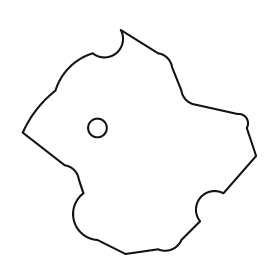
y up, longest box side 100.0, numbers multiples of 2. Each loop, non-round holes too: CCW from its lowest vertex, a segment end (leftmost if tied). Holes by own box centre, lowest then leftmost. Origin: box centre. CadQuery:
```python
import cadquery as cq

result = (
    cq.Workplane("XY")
    .moveTo(-6.0, -48.0)
    .lineTo(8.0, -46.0)
    .threePointArc((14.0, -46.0), (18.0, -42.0))
    .lineTo(26.0, -34.0)
    .threePointArc((26.0, -24.0), (36.0, -22.0))
    .lineTo(50.0, -6.0)
    .lineTo(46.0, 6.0)
    .threePointArc((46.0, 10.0), (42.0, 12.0))
    .lineTo(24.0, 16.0)
    .threePointArc((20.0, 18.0), (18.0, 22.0))
    .lineTo(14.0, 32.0)
    .threePointArc((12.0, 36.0), (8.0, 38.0))
    .lineTo(-8.0, 48.0)
    .threePointArc((-10.0, 38.0), (-20.0, 38.0))
    .threePointArc((-30.0, 32.0), (-36.0, 22.0))
    .threePointArc((-44.0, 14.0), (-50.0, 4.0))
    .lineTo(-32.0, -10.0)
    .threePointArc((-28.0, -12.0), (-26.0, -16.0))
    .lineTo(-24.0, -22.0)
    .threePointArc((-28.0, -34.0), (-18.0, -42.0))
    .close()
    .moveTo(-18.0, 6.0)
    .circle(4.0)
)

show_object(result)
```